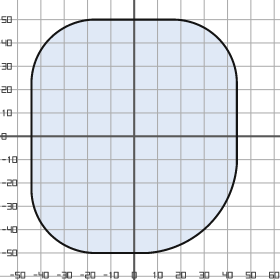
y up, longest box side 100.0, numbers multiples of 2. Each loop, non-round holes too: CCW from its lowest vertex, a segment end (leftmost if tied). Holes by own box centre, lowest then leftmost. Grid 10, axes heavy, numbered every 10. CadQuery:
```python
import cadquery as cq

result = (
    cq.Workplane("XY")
    .moveTo(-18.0, -50.0)
    .lineTo(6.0, -50.0)
    .threePointArc((32.0, -38.0), (44.0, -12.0))
    .lineTo(44.0, 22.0)
    .threePointArc((36.0, 42.0), (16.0, 50.0))
    .lineTo(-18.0, 50.0)
    .threePointArc((-36.0, 42.0), (-44.0, 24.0))
    .lineTo(-44.0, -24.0)
    .threePointArc((-36.0, -42.0), (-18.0, -50.0))
    .close()
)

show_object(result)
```